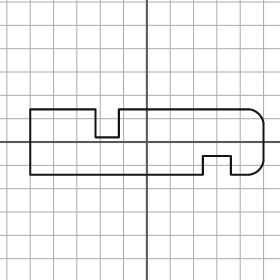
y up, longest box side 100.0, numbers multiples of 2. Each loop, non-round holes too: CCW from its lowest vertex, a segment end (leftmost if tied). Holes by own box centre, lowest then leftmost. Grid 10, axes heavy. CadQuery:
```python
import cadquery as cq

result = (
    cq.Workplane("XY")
    .moveTo(-50.0, -14.0)
    .lineTo(24.0, -14.0)
    .lineTo(24.0, -6.0)
    .lineTo(36.0, -6.0)
    .lineTo(36.0, -14.0)
    .lineTo(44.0, -14.0)
    .threePointArc((48.0, -12.0), (50.0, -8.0))
    .lineTo(50.0, 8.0)
    .threePointArc((48.0, 12.0), (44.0, 14.0))
    .lineTo(-12.0, 14.0)
    .lineTo(-12.0, 2.0)
    .lineTo(-22.0, 2.0)
    .lineTo(-22.0, 14.0)
    .lineTo(-50.0, 14.0)
    .close()
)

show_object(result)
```